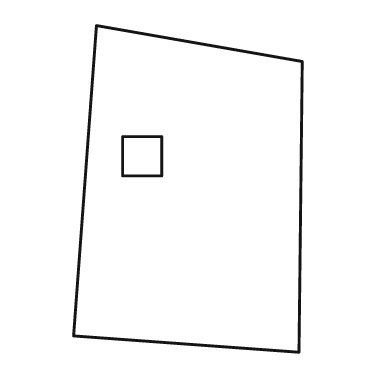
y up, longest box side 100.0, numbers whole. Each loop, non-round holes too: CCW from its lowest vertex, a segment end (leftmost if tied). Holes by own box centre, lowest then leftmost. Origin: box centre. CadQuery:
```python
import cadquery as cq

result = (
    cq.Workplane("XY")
    .moveTo(34.0, -50.0)
    .lineTo(35.0, 39.0)
    .lineTo(-28.0, 50.0)
    .lineTo(-35.0, -45.0)
    .close()
    .moveTo(-20.0, 4.0)
    .lineTo(-8.0, 4.0)
    .lineTo(-8.0, 16.0)
    .lineTo(-20.0, 16.0)
    .close()
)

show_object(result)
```